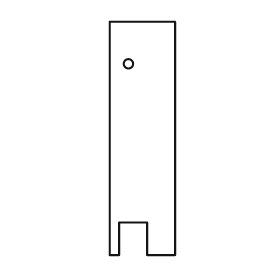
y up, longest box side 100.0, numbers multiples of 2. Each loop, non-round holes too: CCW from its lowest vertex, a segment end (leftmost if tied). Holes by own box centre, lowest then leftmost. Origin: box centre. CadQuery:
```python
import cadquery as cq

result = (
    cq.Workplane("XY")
    .moveTo(-14.0, -50.0)
    .lineTo(-10.0, -50.0)
    .lineTo(-10.0, -36.0)
    .lineTo(2.0, -36.0)
    .lineTo(2.0, -50.0)
    .lineTo(14.0, -50.0)
    .lineTo(14.0, 50.0)
    .lineTo(-14.0, 50.0)
    .close()
    .moveTo(-6.0, 32.0)
    .circle(2.0)
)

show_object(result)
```